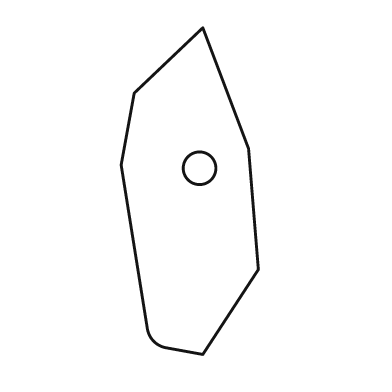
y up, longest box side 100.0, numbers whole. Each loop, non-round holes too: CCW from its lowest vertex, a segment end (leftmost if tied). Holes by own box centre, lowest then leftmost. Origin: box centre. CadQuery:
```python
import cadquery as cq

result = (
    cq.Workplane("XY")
    .moveTo(4.0, -50.0)
    .lineTo(21.0, -24.0)
    .lineTo(18.0, 13.0)
    .lineTo(4.0, 50.0)
    .lineTo(-17.0, 30.0)
    .lineTo(-21.0, 8.0)
    .lineTo(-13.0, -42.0)
    .threePointArc((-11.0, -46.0), (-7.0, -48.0))
    .close()
    .moveTo(3.0, 7.0)
    .circle(5.0)
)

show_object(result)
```